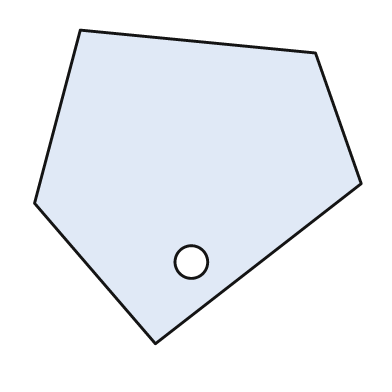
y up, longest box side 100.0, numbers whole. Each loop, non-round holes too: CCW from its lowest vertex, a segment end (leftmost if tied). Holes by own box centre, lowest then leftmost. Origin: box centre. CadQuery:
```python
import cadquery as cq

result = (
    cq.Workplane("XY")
    .moveTo(-13.0, -48.0)
    .lineTo(50.0, 1.0)
    .lineTo(36.0, 41.0)
    .lineTo(-36.0, 48.0)
    .lineTo(-50.0, -5.0)
    .close()
    .moveTo(-2.0, -23.0)
    .circle(5.0)
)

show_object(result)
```